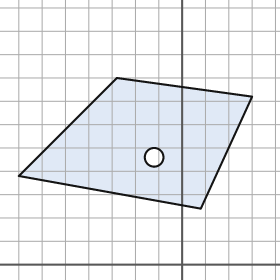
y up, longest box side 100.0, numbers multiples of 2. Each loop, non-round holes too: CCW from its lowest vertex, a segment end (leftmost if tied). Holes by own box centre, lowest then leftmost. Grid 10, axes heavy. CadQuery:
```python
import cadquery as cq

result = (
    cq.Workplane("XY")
    .moveTo(8.0, 24.0)
    .lineTo(30.0, 72.0)
    .lineTo(-28.0, 80.0)
    .lineTo(-70.0, 38.0)
    .close()
    .moveTo(-12.0, 46.0)
    .circle(4.0)
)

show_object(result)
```